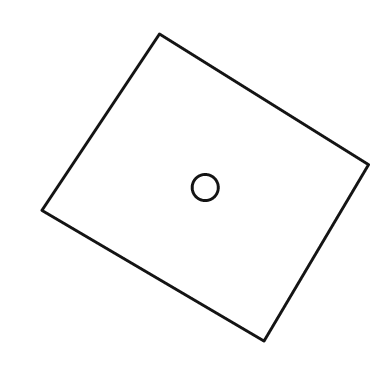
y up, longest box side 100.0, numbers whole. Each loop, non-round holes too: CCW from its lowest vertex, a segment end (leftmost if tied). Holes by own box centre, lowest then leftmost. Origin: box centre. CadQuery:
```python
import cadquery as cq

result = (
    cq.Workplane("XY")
    .moveTo(18.0, -47.0)
    .lineTo(50.0, 7.0)
    .lineTo(-14.0, 47.0)
    .lineTo(-50.0, -7.0)
    .close()
    .moveTo(0.0, 0.0)
    .circle(4.0)
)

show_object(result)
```